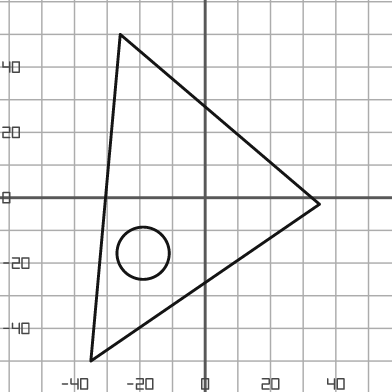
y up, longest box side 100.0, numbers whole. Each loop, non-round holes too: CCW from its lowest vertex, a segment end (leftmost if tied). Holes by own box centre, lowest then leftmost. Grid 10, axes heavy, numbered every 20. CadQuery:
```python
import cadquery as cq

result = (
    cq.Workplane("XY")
    .moveTo(-35.0, -50.0)
    .lineTo(35.0, -2.0)
    .lineTo(-26.0, 50.0)
    .close()
    .moveTo(-19.0, -17.0)
    .circle(8.0)
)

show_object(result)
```